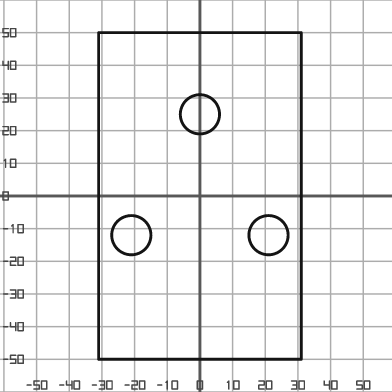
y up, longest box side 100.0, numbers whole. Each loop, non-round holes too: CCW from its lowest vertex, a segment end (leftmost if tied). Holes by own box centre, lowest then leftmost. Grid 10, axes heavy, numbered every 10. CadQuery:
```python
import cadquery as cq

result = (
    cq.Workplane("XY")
    .moveTo(-31.0, -50.0)
    .lineTo(31.0, -50.0)
    .lineTo(31.0, 50.0)
    .lineTo(-31.0, 50.0)
    .close()
    .moveTo(-21.0, -12.0)
    .circle(6.0)
    .moveTo(21.0, -12.0)
    .circle(6.0)
    .moveTo(0.0, 25.0)
    .circle(6.0)
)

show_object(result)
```